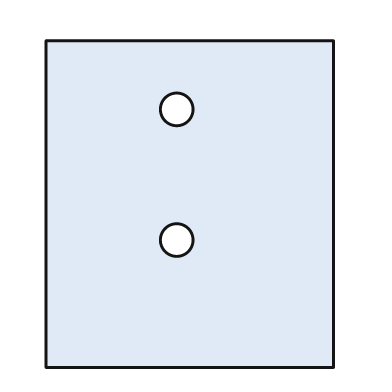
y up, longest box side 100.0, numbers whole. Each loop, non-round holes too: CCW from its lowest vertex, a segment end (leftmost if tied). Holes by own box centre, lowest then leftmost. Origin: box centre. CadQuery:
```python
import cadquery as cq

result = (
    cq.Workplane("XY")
    .moveTo(-44.0, -50.0)
    .lineTo(44.0, -50.0)
    .lineTo(44.0, 50.0)
    .lineTo(-44.0, 50.0)
    .close()
    .moveTo(-4.0, -11.0)
    .circle(5.0)
    .moveTo(-4.0, 29.0)
    .circle(5.0)
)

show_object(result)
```